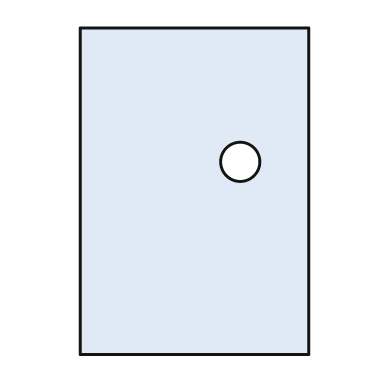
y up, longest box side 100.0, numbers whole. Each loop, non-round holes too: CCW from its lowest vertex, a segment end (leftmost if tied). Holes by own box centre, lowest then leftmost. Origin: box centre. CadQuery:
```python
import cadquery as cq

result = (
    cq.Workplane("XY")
    .moveTo(-35.0, -50.0)
    .lineTo(35.0, -50.0)
    .lineTo(35.0, 50.0)
    .lineTo(-35.0, 50.0)
    .close()
    .moveTo(14.0, 9.0)
    .circle(6.0)
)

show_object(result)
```